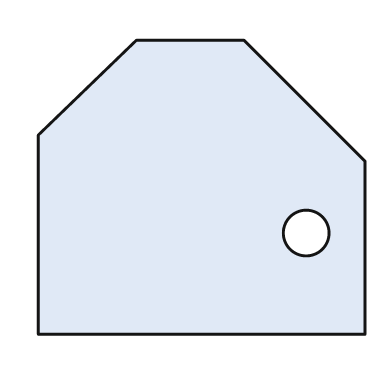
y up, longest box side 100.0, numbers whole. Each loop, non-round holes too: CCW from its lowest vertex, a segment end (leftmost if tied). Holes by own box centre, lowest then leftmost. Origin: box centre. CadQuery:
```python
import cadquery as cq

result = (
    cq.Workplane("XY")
    .moveTo(-50.0, -45.0)
    .lineTo(50.0, -45.0)
    .lineTo(50.0, 8.0)
    .lineTo(13.0, 45.0)
    .lineTo(-20.0, 45.0)
    .lineTo(-50.0, 16.0)
    .close()
    .moveTo(32.0, -14.0)
    .circle(7.0)
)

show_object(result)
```